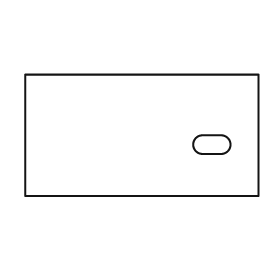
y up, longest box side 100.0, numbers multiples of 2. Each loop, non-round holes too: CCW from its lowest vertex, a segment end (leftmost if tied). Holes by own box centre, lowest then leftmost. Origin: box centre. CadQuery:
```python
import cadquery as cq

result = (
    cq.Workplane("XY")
    .moveTo(-50.0, -26.0)
    .lineTo(50.0, -26.0)
    .lineTo(50.0, 26.0)
    .lineTo(-50.0, 26.0)
    .close()
    .moveTo(26.0, -8.0)
    .lineTo(34.0, -8.0)
    .threePointArc((38.0, -4.0), (34.0, 0.0))
    .lineTo(26.0, 0.0)
    .threePointArc((22.0, -4.0), (26.0, -8.0))
    .close()
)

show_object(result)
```